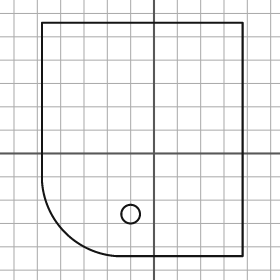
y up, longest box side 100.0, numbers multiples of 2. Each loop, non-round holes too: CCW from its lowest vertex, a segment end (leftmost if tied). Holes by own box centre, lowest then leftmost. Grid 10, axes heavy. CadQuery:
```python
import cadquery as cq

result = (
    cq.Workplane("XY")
    .moveTo(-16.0, -44.0)
    .lineTo(38.0, -44.0)
    .lineTo(38.0, 56.0)
    .lineTo(-48.0, 56.0)
    .lineTo(-48.0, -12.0)
    .threePointArc((-38.0, -34.0), (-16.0, -44.0))
    .close()
    .moveTo(-10.0, -26.0)
    .circle(4.0)
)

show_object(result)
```